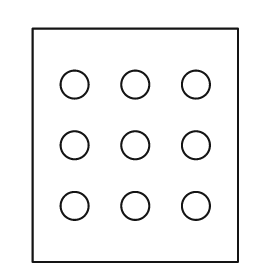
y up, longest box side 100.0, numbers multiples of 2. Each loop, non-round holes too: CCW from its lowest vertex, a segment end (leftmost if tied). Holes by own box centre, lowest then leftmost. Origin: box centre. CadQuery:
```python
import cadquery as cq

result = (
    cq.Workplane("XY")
    .moveTo(-44.0, -50.0)
    .lineTo(44.0, -50.0)
    .lineTo(44.0, 50.0)
    .lineTo(-44.0, 50.0)
    .close()
    .moveTo(-26.0, -26.0)
    .circle(6.0)
    .moveTo(0.0, -26.0)
    .circle(6.0)
    .moveTo(26.0, -26.0)
    .circle(6.0)
    .moveTo(-26.0, 0.0)
    .circle(6.0)
    .moveTo(0.0, 0.0)
    .circle(6.0)
    .moveTo(26.0, 0.0)
    .circle(6.0)
    .moveTo(-26.0, 26.0)
    .circle(6.0)
    .moveTo(0.0, 26.0)
    .circle(6.0)
    .moveTo(26.0, 26.0)
    .circle(6.0)
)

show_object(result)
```